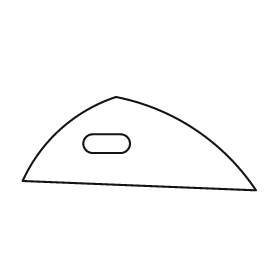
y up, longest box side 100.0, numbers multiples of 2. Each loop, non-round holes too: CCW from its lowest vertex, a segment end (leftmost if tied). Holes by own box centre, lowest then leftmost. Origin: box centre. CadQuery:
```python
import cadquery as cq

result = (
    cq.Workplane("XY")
    .moveTo(50.0, -20.0)
    .threePointArc((24.0, 6.0), (-10.0, 20.0))
    .threePointArc((-34.0, 6.0), (-50.0, -16.0))
    .close()
    .moveTo(-20.0, -4.0)
    .lineTo(-8.0, -4.0)
    .threePointArc((-4.0, 0.0), (-8.0, 4.0))
    .lineTo(-20.0, 4.0)
    .threePointArc((-24.0, 0.0), (-20.0, -4.0))
    .close()
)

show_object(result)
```